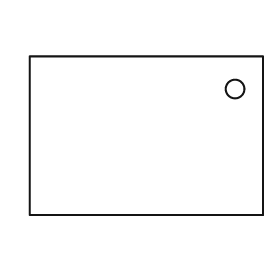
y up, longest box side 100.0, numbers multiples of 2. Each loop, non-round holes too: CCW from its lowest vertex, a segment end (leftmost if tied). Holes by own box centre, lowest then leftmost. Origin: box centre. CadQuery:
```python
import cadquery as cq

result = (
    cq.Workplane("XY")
    .moveTo(-50.0, -34.0)
    .lineTo(50.0, -34.0)
    .lineTo(50.0, 34.0)
    .lineTo(-50.0, 34.0)
    .close()
    .moveTo(38.0, 20.0)
    .circle(4.0)
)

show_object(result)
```